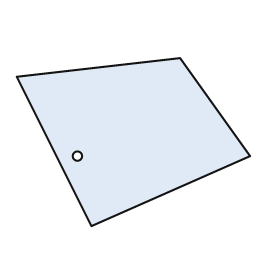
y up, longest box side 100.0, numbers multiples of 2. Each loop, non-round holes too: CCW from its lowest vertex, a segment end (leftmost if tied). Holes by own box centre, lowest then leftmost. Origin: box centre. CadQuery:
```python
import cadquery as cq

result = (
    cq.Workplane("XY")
    .moveTo(-18.0, -36.0)
    .lineTo(50.0, -6.0)
    .lineTo(20.0, 36.0)
    .lineTo(-50.0, 28.0)
    .close()
    .moveTo(-24.0, -6.0)
    .circle(2.0)
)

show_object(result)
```